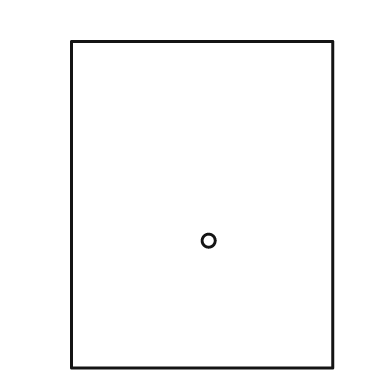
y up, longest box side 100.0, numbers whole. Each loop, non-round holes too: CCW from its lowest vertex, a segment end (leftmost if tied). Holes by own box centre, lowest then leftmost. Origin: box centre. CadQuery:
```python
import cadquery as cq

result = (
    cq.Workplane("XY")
    .moveTo(-40.0, -50.0)
    .lineTo(40.0, -50.0)
    .lineTo(40.0, 50.0)
    .lineTo(-40.0, 50.0)
    .close()
    .moveTo(2.0, -11.0)
    .circle(2.0)
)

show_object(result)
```